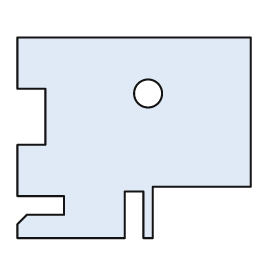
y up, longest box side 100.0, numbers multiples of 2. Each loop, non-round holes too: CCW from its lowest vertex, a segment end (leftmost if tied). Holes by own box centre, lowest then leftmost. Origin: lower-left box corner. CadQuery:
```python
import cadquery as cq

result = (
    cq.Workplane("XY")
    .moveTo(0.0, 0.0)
    .lineTo(46.0, 0.0)
    .lineTo(46.0, 20.0)
    .lineTo(54.0, 20.0)
    .lineTo(54.0, 0.0)
    .lineTo(58.0, 0.0)
    .lineTo(58.0, 22.0)
    .lineTo(100.0, 22.0)
    .lineTo(100.0, 86.0)
    .lineTo(0.0, 86.0)
    .lineTo(0.0, 64.0)
    .lineTo(12.0, 64.0)
    .lineTo(12.0, 40.0)
    .lineTo(0.0, 40.0)
    .lineTo(0.0, 18.0)
    .lineTo(20.0, 18.0)
    .lineTo(20.0, 10.0)
    .lineTo(4.0, 10.0)
    .lineTo(0.0, 6.0)
    .close()
    .moveTo(56.0, 62.0)
    .circle(6.0)
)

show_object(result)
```